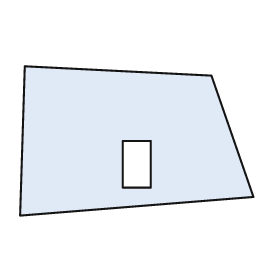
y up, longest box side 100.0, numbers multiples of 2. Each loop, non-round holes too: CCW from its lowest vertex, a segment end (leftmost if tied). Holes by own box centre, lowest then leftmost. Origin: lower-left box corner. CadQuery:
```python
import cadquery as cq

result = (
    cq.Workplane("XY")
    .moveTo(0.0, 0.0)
    .lineTo(100.0, 8.0)
    .lineTo(82.0, 60.0)
    .lineTo(2.0, 64.0)
    .close()
    .moveTo(44.0, 12.0)
    .lineTo(56.0, 12.0)
    .lineTo(56.0, 32.0)
    .lineTo(44.0, 32.0)
    .close()
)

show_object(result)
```